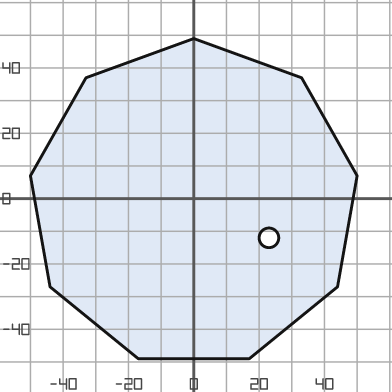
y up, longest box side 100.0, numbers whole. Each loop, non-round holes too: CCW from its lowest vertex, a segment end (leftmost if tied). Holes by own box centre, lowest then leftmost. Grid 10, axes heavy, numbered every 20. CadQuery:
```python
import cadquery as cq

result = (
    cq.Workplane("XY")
    .moveTo(-17.0, -49.0)
    .lineTo(17.0, -49.0)
    .lineTo(44.0, -27.0)
    .lineTo(50.0, 7.0)
    .lineTo(33.0, 37.0)
    .lineTo(0.0, 49.0)
    .lineTo(-33.0, 37.0)
    .lineTo(-50.0, 7.0)
    .lineTo(-44.0, -27.0)
    .close()
    .moveTo(23.0, -12.0)
    .circle(3.0)
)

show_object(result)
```